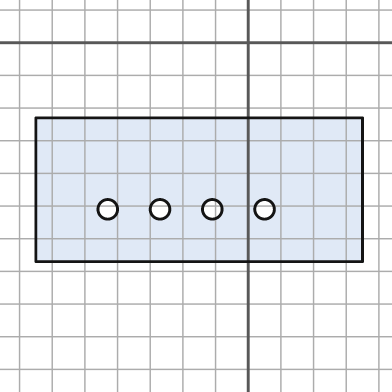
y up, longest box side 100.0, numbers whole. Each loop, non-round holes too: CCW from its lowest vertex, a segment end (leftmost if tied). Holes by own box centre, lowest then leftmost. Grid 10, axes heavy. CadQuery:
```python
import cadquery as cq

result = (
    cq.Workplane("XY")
    .moveTo(-65.0, -67.0)
    .lineTo(35.0, -67.0)
    .lineTo(35.0, -23.0)
    .lineTo(-65.0, -23.0)
    .close()
    .moveTo(-43.0, -51.0)
    .circle(3.0)
    .moveTo(-27.0, -51.0)
    .circle(3.0)
    .moveTo(-11.0, -51.0)
    .circle(3.0)
    .moveTo(5.0, -51.0)
    .circle(3.0)
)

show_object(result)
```